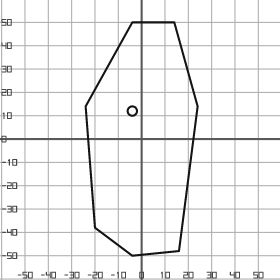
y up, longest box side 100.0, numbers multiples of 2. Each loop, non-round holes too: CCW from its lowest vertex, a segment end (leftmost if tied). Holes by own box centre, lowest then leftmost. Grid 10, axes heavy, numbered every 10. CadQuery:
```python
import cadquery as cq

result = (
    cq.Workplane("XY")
    .moveTo(-4.0, -50.0)
    .lineTo(16.0, -48.0)
    .lineTo(24.0, 14.0)
    .lineTo(14.0, 50.0)
    .lineTo(-4.0, 50.0)
    .lineTo(-24.0, 14.0)
    .lineTo(-20.0, -38.0)
    .close()
    .moveTo(-4.0, 12.0)
    .circle(2.0)
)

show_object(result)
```